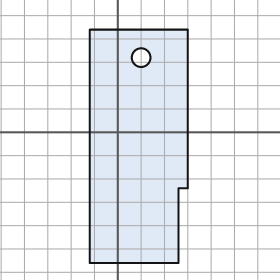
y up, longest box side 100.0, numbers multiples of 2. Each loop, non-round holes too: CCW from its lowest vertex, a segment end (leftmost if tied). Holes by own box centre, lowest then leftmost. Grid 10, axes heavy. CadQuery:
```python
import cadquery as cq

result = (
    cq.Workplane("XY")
    .moveTo(-12.0, -56.0)
    .lineTo(26.0, -56.0)
    .lineTo(26.0, -24.0)
    .lineTo(30.0, -24.0)
    .lineTo(30.0, 44.0)
    .lineTo(-12.0, 44.0)
    .close()
    .moveTo(10.0, 32.0)
    .circle(4.0)
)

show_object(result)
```